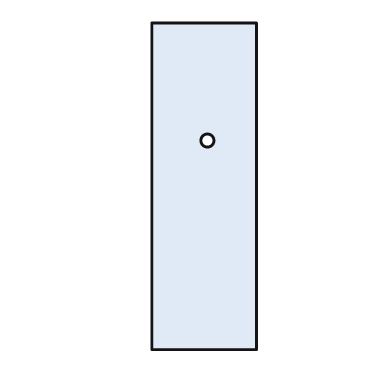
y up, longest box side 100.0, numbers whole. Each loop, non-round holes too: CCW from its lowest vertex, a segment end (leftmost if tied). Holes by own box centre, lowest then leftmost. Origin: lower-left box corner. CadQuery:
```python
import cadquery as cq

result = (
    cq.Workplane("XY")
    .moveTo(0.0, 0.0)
    .lineTo(32.0, 0.0)
    .lineTo(32.0, 100.0)
    .lineTo(0.0, 100.0)
    .close()
    .moveTo(17.0, 64.0)
    .circle(2.0)
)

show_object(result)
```